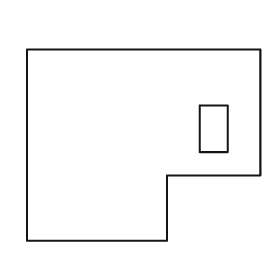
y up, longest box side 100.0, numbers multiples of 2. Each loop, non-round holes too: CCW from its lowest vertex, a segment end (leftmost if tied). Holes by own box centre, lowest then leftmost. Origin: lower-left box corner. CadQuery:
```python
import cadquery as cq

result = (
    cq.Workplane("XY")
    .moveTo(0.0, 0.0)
    .lineTo(60.0, 0.0)
    .lineTo(60.0, 28.0)
    .lineTo(100.0, 28.0)
    .lineTo(100.0, 82.0)
    .lineTo(0.0, 82.0)
    .close()
    .moveTo(74.0, 38.0)
    .lineTo(86.0, 38.0)
    .lineTo(86.0, 58.0)
    .lineTo(74.0, 58.0)
    .close()
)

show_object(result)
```